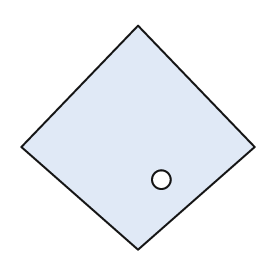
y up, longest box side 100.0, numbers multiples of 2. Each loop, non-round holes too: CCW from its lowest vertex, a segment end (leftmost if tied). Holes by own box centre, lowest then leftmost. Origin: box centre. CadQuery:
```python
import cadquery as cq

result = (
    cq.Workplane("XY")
    .moveTo(0.0, -48.0)
    .lineTo(50.0, -4.0)
    .lineTo(0.0, 48.0)
    .lineTo(-50.0, -4.0)
    .close()
    .moveTo(10.0, -18.0)
    .circle(4.0)
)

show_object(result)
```